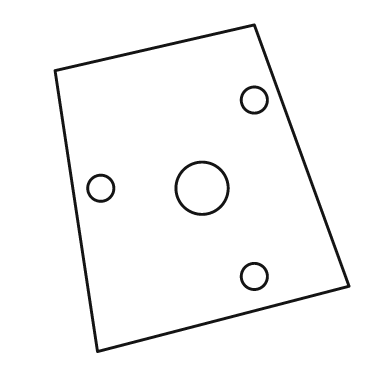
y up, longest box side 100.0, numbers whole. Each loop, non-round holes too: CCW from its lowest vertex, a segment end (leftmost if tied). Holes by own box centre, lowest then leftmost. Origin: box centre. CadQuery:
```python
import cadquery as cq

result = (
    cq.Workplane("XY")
    .moveTo(-32.0, -50.0)
    .lineTo(45.0, -30.0)
    .lineTo(16.0, 50.0)
    .lineTo(-45.0, 36.0)
    .close()
    .moveTo(16.0, -27.0)
    .circle(4.0)
    .moveTo(-31.0, 0.0)
    .circle(4.0)
    .moveTo(0.0, 0.0)
    .circle(8.0)
    .moveTo(16.0, 27.0)
    .circle(4.0)
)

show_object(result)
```